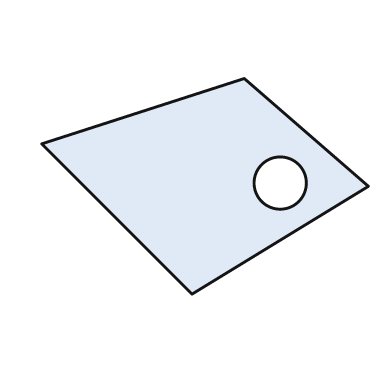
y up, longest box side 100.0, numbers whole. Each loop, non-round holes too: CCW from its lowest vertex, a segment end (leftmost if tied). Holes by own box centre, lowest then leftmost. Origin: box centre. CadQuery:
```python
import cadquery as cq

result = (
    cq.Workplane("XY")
    .moveTo(-4.0, -33.0)
    .lineTo(50.0, 0.0)
    .lineTo(12.0, 33.0)
    .lineTo(-50.0, 13.0)
    .close()
    .moveTo(23.0, 1.0)
    .circle(8.0)
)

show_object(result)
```